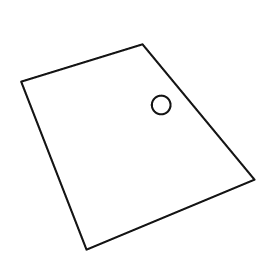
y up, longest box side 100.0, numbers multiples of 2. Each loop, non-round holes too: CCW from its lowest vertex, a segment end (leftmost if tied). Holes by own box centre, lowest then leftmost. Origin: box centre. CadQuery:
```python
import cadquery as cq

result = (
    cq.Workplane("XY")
    .moveTo(-22.0, -44.0)
    .lineTo(50.0, -14.0)
    .lineTo(2.0, 44.0)
    .lineTo(-50.0, 28.0)
    .close()
    .moveTo(10.0, 18.0)
    .circle(4.0)
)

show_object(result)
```